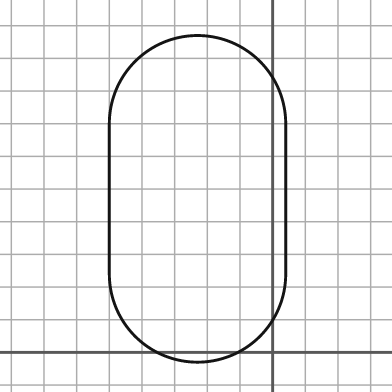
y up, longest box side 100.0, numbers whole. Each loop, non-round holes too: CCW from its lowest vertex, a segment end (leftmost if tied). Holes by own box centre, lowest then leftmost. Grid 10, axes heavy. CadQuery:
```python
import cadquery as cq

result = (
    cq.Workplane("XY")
    .moveTo(-50.0, 24.0)
    .threePointArc((-23.0, -3.0), (4.0, 24.0))
    .lineTo(4.0, 70.0)
    .threePointArc((-23.0, 97.0), (-50.0, 70.0))
    .close()
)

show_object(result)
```